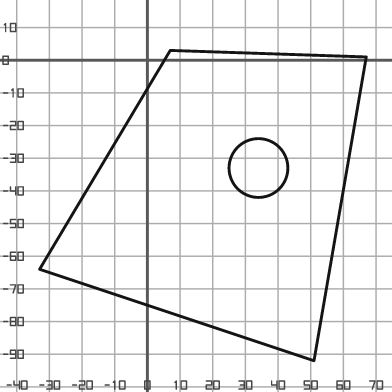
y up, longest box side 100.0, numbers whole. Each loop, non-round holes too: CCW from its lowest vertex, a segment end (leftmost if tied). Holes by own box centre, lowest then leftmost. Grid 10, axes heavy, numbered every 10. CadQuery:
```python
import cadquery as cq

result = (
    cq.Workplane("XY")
    .moveTo(51.0, -92.0)
    .lineTo(67.0, 1.0)
    .lineTo(7.0, 3.0)
    .lineTo(-33.0, -64.0)
    .close()
    .moveTo(34.0, -33.0)
    .circle(9.0)
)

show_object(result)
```